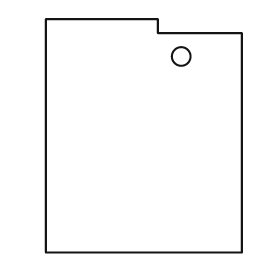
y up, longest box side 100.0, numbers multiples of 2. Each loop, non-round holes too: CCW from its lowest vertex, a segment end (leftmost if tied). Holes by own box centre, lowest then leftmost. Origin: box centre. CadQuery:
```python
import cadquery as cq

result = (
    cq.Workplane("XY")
    .moveTo(-42.0, -50.0)
    .lineTo(42.0, -50.0)
    .lineTo(42.0, 44.0)
    .lineTo(6.0, 44.0)
    .lineTo(6.0, 50.0)
    .lineTo(-42.0, 50.0)
    .close()
    .moveTo(16.0, 34.0)
    .circle(4.0)
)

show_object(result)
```